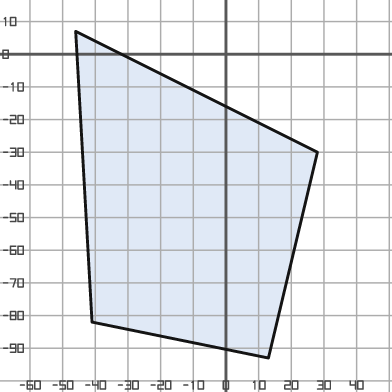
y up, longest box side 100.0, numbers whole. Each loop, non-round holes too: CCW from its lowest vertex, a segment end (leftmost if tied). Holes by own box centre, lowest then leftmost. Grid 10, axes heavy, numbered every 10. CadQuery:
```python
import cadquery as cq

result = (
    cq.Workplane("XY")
    .moveTo(13.0, -93.0)
    .lineTo(28.0, -30.0)
    .lineTo(-46.0, 7.0)
    .lineTo(-41.0, -82.0)
    .close()
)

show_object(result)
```